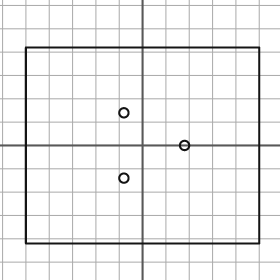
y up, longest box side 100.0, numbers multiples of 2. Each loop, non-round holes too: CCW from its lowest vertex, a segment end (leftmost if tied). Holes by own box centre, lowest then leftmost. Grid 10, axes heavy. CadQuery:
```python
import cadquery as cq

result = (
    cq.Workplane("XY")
    .moveTo(-50.0, -42.0)
    .lineTo(50.0, -42.0)
    .lineTo(50.0, 42.0)
    .lineTo(-50.0, 42.0)
    .close()
    .moveTo(-8.0, -14.0)
    .circle(2.0)
    .moveTo(18.0, 0.0)
    .circle(2.0)
    .moveTo(-8.0, 14.0)
    .circle(2.0)
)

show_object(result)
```